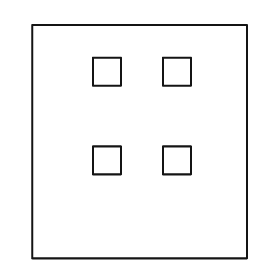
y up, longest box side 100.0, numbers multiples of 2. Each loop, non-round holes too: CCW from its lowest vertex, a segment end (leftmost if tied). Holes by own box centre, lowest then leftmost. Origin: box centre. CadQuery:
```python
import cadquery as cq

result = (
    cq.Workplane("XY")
    .moveTo(-46.0, -50.0)
    .lineTo(46.0, -50.0)
    .lineTo(46.0, 50.0)
    .lineTo(-46.0, 50.0)
    .close()
    .moveTo(-20.0, -14.0)
    .lineTo(-8.0, -14.0)
    .lineTo(-8.0, -2.0)
    .lineTo(-20.0, -2.0)
    .close()
    .moveTo(10.0, -14.0)
    .lineTo(22.0, -14.0)
    .lineTo(22.0, -2.0)
    .lineTo(10.0, -2.0)
    .close()
    .moveTo(-20.0, 24.0)
    .lineTo(-8.0, 24.0)
    .lineTo(-8.0, 36.0)
    .lineTo(-20.0, 36.0)
    .close()
    .moveTo(10.0, 24.0)
    .lineTo(22.0, 24.0)
    .lineTo(22.0, 36.0)
    .lineTo(10.0, 36.0)
    .close()
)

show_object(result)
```